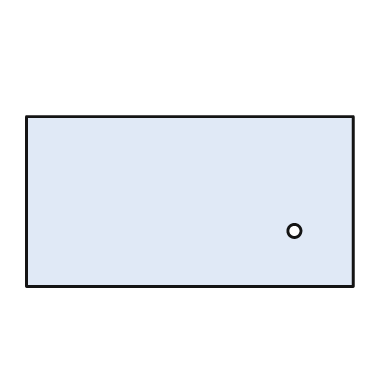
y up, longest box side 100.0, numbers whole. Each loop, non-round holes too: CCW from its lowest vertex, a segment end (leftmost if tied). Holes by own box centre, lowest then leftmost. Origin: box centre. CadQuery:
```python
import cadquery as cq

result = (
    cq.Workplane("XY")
    .moveTo(-50.0, -26.0)
    .lineTo(50.0, -26.0)
    .lineTo(50.0, 26.0)
    .lineTo(-50.0, 26.0)
    .close()
    .moveTo(32.0, -9.0)
    .circle(2.0)
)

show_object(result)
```